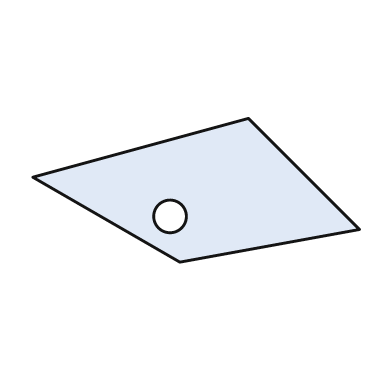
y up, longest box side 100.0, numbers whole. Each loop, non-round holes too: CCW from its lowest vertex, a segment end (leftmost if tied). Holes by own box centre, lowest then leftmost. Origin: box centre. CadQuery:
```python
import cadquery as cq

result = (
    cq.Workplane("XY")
    .moveTo(-5.0, -22.0)
    .lineTo(50.0, -12.0)
    .lineTo(16.0, 22.0)
    .lineTo(-50.0, 4.0)
    .close()
    .moveTo(-8.0, -8.0)
    .circle(5.0)
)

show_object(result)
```